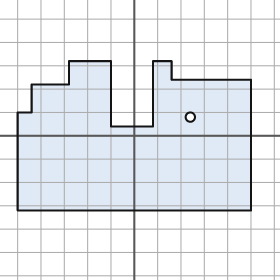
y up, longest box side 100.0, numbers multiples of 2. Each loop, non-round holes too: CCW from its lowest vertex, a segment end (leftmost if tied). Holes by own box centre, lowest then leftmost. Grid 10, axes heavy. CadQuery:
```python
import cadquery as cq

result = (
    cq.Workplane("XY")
    .moveTo(-50.0, -32.0)
    .lineTo(50.0, -32.0)
    .lineTo(50.0, 24.0)
    .lineTo(16.0, 24.0)
    .lineTo(16.0, 32.0)
    .lineTo(8.0, 32.0)
    .lineTo(8.0, 4.0)
    .lineTo(-10.0, 4.0)
    .lineTo(-10.0, 32.0)
    .lineTo(-28.0, 32.0)
    .lineTo(-28.0, 22.0)
    .lineTo(-44.0, 22.0)
    .lineTo(-44.0, 10.0)
    .lineTo(-50.0, 10.0)
    .close()
    .moveTo(24.0, 8.0)
    .circle(2.0)
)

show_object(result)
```